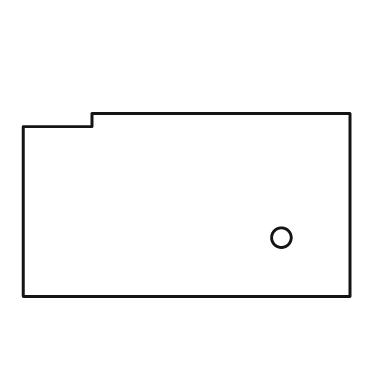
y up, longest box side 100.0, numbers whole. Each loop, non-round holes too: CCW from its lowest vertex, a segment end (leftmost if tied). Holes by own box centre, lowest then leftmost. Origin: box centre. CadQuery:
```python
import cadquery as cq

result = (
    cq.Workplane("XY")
    .moveTo(-50.0, -28.0)
    .lineTo(50.0, -28.0)
    .lineTo(50.0, 28.0)
    .lineTo(-29.0, 28.0)
    .lineTo(-29.0, 24.0)
    .lineTo(-50.0, 24.0)
    .close()
    .moveTo(29.0, -10.0)
    .circle(3.0)
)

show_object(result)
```